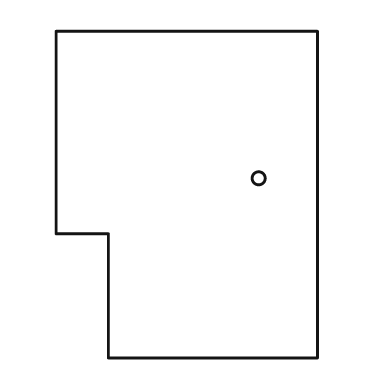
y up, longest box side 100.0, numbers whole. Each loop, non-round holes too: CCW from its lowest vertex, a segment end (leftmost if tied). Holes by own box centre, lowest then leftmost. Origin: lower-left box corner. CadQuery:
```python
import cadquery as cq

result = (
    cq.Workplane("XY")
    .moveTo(16.0, 0.0)
    .lineTo(80.0, 0.0)
    .lineTo(80.0, 100.0)
    .lineTo(0.0, 100.0)
    .lineTo(0.0, 38.0)
    .lineTo(16.0, 38.0)
    .close()
    .moveTo(62.0, 55.0)
    .circle(2.0)
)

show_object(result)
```